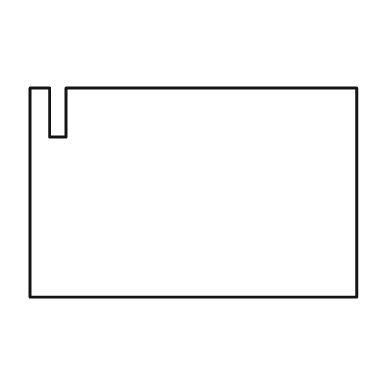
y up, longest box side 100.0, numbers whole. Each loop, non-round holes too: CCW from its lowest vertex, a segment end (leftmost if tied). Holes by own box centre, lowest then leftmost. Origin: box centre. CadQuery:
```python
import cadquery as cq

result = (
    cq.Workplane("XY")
    .moveTo(-50.0, -32.0)
    .lineTo(50.0, -32.0)
    .lineTo(50.0, 32.0)
    .lineTo(-39.0, 32.0)
    .lineTo(-39.0, 17.0)
    .lineTo(-44.0, 17.0)
    .lineTo(-44.0, 32.0)
    .lineTo(-50.0, 32.0)
    .close()
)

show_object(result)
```